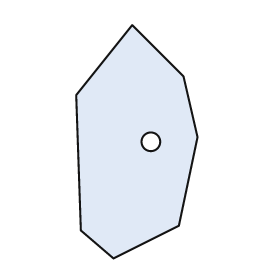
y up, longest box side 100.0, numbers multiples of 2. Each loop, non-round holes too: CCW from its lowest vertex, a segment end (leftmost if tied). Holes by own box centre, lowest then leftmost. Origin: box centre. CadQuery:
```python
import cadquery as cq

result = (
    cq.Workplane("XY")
    .moveTo(-10.0, -50.0)
    .lineTo(18.0, -36.0)
    .lineTo(26.0, 2.0)
    .lineTo(20.0, 28.0)
    .lineTo(-2.0, 50.0)
    .lineTo(-26.0, 20.0)
    .lineTo(-24.0, -38.0)
    .close()
    .moveTo(6.0, 0.0)
    .circle(4.0)
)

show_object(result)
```